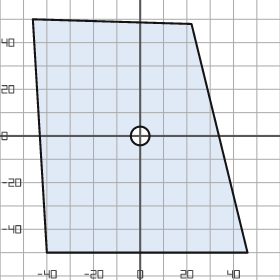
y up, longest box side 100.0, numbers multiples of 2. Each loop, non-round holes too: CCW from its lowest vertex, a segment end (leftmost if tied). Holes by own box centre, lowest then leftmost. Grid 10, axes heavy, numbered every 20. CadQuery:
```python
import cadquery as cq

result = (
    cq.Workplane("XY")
    .moveTo(-40.0, -50.0)
    .lineTo(46.0, -50.0)
    .lineTo(22.0, 48.0)
    .lineTo(-46.0, 50.0)
    .close()
    .moveTo(0.0, 0.0)
    .circle(4.0)
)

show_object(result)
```